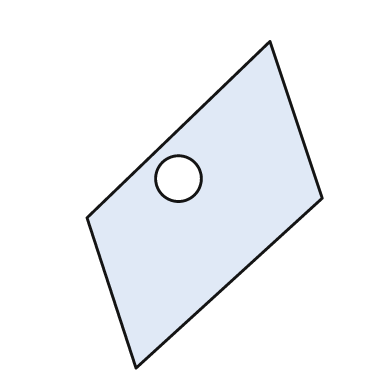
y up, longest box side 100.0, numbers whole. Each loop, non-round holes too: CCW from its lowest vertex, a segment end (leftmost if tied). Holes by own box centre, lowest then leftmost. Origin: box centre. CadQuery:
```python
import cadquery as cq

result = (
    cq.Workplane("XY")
    .moveTo(-21.0, -50.0)
    .lineTo(36.0, 2.0)
    .lineTo(20.0, 50.0)
    .lineTo(-36.0, -4.0)
    .close()
    .moveTo(-8.0, 8.0)
    .circle(7.0)
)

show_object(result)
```